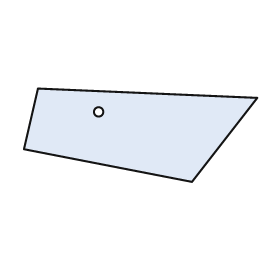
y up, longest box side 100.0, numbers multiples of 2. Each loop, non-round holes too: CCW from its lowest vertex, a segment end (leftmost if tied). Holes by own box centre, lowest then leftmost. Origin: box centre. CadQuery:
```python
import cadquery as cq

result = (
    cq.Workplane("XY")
    .moveTo(22.0, -20.0)
    .lineTo(50.0, 16.0)
    .lineTo(-44.0, 20.0)
    .lineTo(-50.0, -6.0)
    .close()
    .moveTo(-18.0, 10.0)
    .circle(2.0)
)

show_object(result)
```